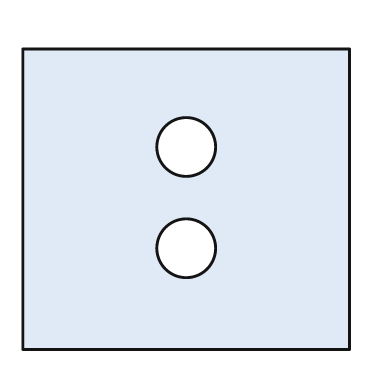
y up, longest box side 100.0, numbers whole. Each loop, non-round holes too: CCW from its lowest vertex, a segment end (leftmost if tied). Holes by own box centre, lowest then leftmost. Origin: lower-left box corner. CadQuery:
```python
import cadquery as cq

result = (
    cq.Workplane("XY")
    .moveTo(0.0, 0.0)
    .lineTo(100.0, 0.0)
    .lineTo(100.0, 92.0)
    .lineTo(0.0, 92.0)
    .close()
    .moveTo(50.0, 31.0)
    .circle(9.0)
    .moveTo(50.0, 62.0)
    .circle(9.0)
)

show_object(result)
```